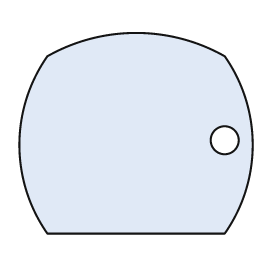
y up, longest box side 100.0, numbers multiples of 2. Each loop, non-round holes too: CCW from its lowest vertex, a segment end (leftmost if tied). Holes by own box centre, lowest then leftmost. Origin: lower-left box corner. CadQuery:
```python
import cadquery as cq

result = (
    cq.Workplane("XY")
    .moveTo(12.0, 0.0)
    .lineTo(88.0, 0.0)
    .threePointArc((100.0, 38.0), (88.0, 76.0))
    .threePointArc((50.0, 86.0), (12.0, 76.0))
    .threePointArc((0.0, 38.0), (12.0, 0.0))
    .close()
    .moveTo(88.0, 40.0)
    .circle(6.0)
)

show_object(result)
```